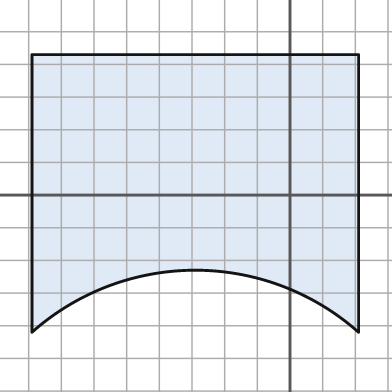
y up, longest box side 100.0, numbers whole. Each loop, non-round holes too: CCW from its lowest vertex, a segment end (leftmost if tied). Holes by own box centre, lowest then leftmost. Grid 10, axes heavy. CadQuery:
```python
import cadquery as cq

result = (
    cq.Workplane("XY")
    .moveTo(-79.0, -42.0)
    .threePointArc((-29.0, -23.0), (21.0, -42.0))
    .lineTo(21.0, 43.0)
    .lineTo(-79.0, 43.0)
    .close()
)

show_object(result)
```